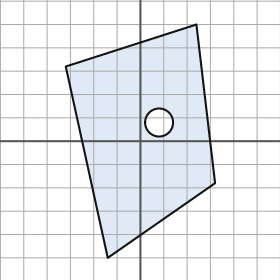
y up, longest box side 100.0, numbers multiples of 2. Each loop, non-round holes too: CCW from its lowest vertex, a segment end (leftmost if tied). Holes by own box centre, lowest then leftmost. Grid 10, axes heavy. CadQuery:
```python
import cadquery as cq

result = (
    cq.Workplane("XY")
    .moveTo(-14.0, -50.0)
    .lineTo(32.0, -18.0)
    .lineTo(24.0, 50.0)
    .lineTo(-32.0, 32.0)
    .close()
    .moveTo(8.0, 8.0)
    .circle(6.0)
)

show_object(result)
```